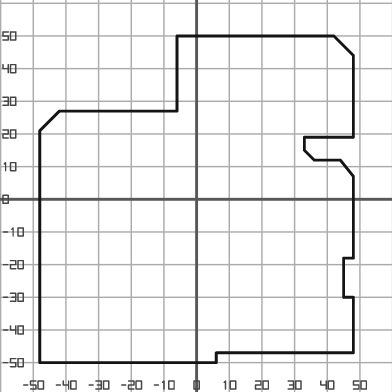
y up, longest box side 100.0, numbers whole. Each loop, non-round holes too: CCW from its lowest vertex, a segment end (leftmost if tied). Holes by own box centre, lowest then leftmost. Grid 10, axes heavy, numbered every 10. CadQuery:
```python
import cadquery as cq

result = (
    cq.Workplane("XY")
    .moveTo(-48.0, -50.0)
    .lineTo(6.0, -50.0)
    .lineTo(6.0, -47.0)
    .lineTo(48.0, -47.0)
    .lineTo(48.0, -30.0)
    .lineTo(45.0, -30.0)
    .lineTo(45.0, -18.0)
    .lineTo(48.0, -18.0)
    .lineTo(48.0, 7.0)
    .lineTo(44.0, 12.0)
    .lineTo(36.0, 12.0)
    .lineTo(33.0, 15.0)
    .lineTo(33.0, 19.0)
    .lineTo(48.0, 19.0)
    .lineTo(48.0, 44.0)
    .lineTo(42.0, 50.0)
    .lineTo(-6.0, 50.0)
    .lineTo(-6.0, 27.0)
    .lineTo(-42.0, 27.0)
    .lineTo(-48.0, 21.0)
    .close()
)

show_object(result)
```